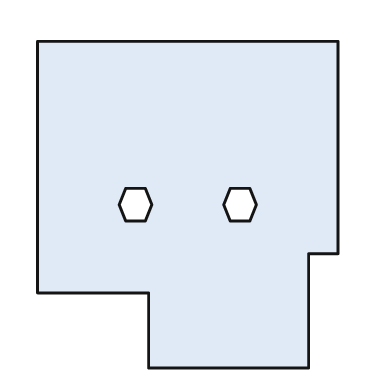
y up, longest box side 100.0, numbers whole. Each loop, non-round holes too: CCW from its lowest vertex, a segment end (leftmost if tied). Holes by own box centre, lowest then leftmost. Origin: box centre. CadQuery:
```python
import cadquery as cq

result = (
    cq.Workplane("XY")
    .moveTo(-12.0, -50.0)
    .lineTo(37.0, -50.0)
    .lineTo(37.0, -15.0)
    .lineTo(46.0, -15.0)
    .lineTo(46.0, 50.0)
    .lineTo(-46.0, 50.0)
    .lineTo(-46.0, -27.0)
    .lineTo(-12.0, -27.0)
    .close()
    .moveTo(-19.0, -5.0)
    .lineTo(-13.0, -5.0)
    .lineTo(-11.0, 0.0)
    .lineTo(-13.0, 5.0)
    .lineTo(-19.0, 5.0)
    .lineTo(-21.0, 0.0)
    .close()
    .moveTo(13.0, -5.0)
    .lineTo(19.0, -5.0)
    .lineTo(21.0, 0.0)
    .lineTo(19.0, 5.0)
    .lineTo(13.0, 5.0)
    .lineTo(11.0, 0.0)
    .close()
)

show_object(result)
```